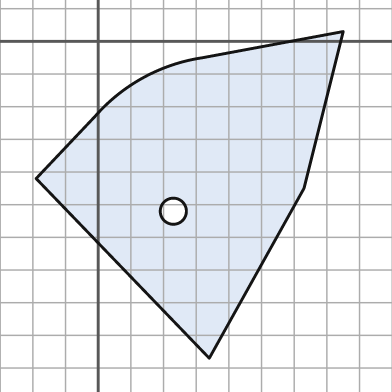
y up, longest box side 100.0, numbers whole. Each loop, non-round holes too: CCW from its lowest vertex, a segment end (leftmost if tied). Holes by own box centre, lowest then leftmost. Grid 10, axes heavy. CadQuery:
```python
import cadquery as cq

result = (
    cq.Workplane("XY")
    .moveTo(34.0, -97.0)
    .lineTo(63.0, -45.0)
    .lineTo(75.0, 3.0)
    .lineTo(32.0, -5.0)
    .threePointArc((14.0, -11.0), (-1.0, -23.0))
    .lineTo(-19.0, -42.0)
    .close()
    .moveTo(23.0, -52.0)
    .circle(4.0)
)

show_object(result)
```